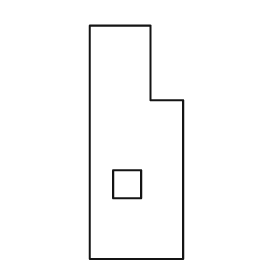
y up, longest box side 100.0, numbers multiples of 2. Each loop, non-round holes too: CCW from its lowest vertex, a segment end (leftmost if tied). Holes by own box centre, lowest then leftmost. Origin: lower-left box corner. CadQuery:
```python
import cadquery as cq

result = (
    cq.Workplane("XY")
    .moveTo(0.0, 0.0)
    .lineTo(40.0, 0.0)
    .lineTo(40.0, 68.0)
    .lineTo(26.0, 68.0)
    .lineTo(26.0, 100.0)
    .lineTo(0.0, 100.0)
    .close()
    .moveTo(10.0, 26.0)
    .lineTo(22.0, 26.0)
    .lineTo(22.0, 38.0)
    .lineTo(10.0, 38.0)
    .close()
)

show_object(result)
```